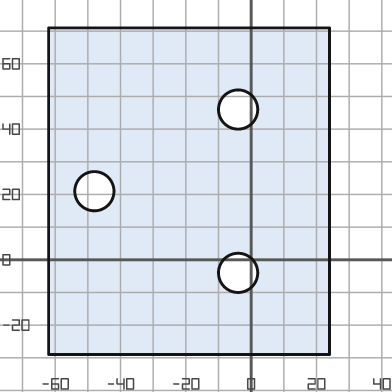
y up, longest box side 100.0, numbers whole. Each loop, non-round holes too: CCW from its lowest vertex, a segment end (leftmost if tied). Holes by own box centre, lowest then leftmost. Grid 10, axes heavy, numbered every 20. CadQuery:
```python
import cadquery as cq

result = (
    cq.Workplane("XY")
    .moveTo(-62.0, -29.0)
    .lineTo(24.0, -29.0)
    .lineTo(24.0, 71.0)
    .lineTo(-62.0, 71.0)
    .close()
    .moveTo(-4.0, -4.0)
    .circle(6.0)
    .moveTo(-48.0, 21.0)
    .circle(6.0)
    .moveTo(-4.0, 46.0)
    .circle(6.0)
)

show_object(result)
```